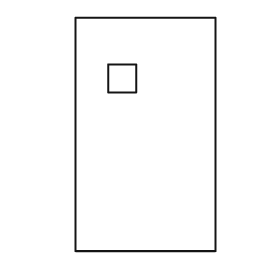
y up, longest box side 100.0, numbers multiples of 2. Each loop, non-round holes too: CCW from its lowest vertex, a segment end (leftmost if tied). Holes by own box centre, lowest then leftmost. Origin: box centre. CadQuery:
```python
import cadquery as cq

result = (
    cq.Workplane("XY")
    .moveTo(-30.0, -50.0)
    .lineTo(30.0, -50.0)
    .lineTo(30.0, 50.0)
    .lineTo(-30.0, 50.0)
    .close()
    .moveTo(-16.0, 18.0)
    .lineTo(-4.0, 18.0)
    .lineTo(-4.0, 30.0)
    .lineTo(-16.0, 30.0)
    .close()
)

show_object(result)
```